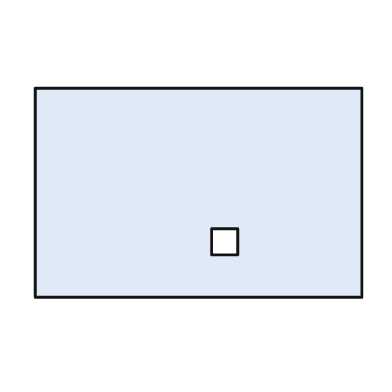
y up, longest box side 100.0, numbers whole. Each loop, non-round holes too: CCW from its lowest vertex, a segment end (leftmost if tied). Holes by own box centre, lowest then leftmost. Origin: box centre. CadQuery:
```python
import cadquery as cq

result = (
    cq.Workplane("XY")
    .moveTo(-50.0, -32.0)
    .lineTo(50.0, -32.0)
    .lineTo(50.0, 32.0)
    .lineTo(-50.0, 32.0)
    .close()
    .moveTo(4.0, -19.0)
    .lineTo(12.0, -19.0)
    .lineTo(12.0, -11.0)
    .lineTo(4.0, -11.0)
    .close()
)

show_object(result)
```